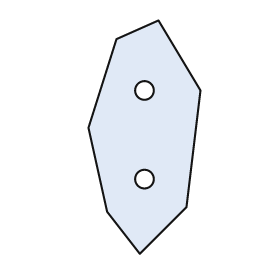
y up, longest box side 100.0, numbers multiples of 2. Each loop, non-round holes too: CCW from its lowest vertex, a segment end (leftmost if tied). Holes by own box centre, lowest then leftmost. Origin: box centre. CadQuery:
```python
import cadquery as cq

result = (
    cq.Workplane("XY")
    .moveTo(-2.0, -50.0)
    .lineTo(18.0, -30.0)
    .lineTo(24.0, 20.0)
    .lineTo(6.0, 50.0)
    .lineTo(-12.0, 42.0)
    .lineTo(-24.0, 4.0)
    .lineTo(-16.0, -32.0)
    .close()
    .moveTo(0.0, -18.0)
    .circle(4.0)
    .moveTo(0.0, 20.0)
    .circle(4.0)
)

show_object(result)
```